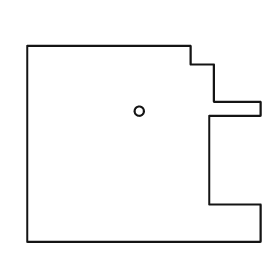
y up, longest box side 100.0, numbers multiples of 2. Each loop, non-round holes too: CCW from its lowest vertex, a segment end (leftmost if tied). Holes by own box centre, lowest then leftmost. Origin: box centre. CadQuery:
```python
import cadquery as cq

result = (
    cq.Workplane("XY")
    .moveTo(-50.0, -42.0)
    .lineTo(50.0, -42.0)
    .lineTo(50.0, -26.0)
    .lineTo(28.0, -26.0)
    .lineTo(28.0, 12.0)
    .lineTo(50.0, 12.0)
    .lineTo(50.0, 18.0)
    .lineTo(30.0, 18.0)
    .lineTo(30.0, 34.0)
    .lineTo(20.0, 34.0)
    .lineTo(20.0, 42.0)
    .lineTo(-50.0, 42.0)
    .close()
    .moveTo(-2.0, 14.0)
    .circle(2.0)
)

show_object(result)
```